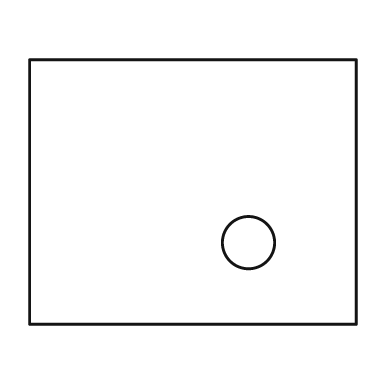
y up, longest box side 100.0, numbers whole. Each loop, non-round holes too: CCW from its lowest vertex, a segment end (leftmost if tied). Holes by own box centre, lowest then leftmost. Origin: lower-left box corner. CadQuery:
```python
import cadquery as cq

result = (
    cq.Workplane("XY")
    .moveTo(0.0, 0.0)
    .lineTo(100.0, 0.0)
    .lineTo(100.0, 81.0)
    .lineTo(0.0, 81.0)
    .close()
    .moveTo(67.0, 25.0)
    .circle(8.0)
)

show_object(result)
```